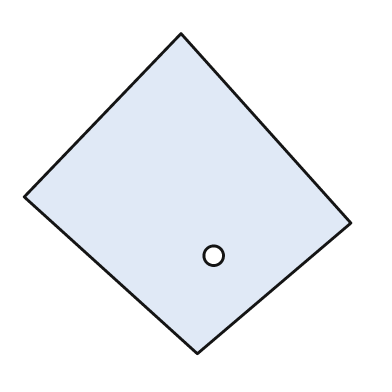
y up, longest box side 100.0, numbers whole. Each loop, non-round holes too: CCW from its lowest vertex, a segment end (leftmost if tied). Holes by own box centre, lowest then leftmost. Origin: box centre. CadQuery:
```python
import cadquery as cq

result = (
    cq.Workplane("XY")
    .moveTo(3.0, -49.0)
    .lineTo(50.0, -9.0)
    .lineTo(-2.0, 49.0)
    .lineTo(-50.0, -1.0)
    .close()
    .moveTo(8.0, -19.0)
    .circle(3.0)
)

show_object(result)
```